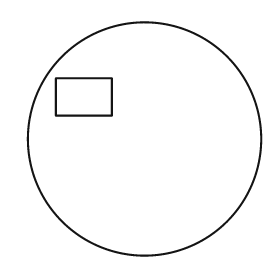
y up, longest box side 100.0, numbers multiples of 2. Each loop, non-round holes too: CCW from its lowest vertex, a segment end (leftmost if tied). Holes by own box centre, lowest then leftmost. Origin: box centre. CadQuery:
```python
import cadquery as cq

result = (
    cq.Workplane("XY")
    .moveTo(0.0, 0.0)
    .circle(50.0)
    .moveTo(-38.0, 10.0)
    .lineTo(-14.0, 10.0)
    .lineTo(-14.0, 26.0)
    .lineTo(-38.0, 26.0)
    .close()
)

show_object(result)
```